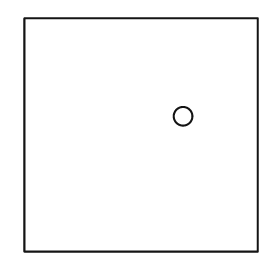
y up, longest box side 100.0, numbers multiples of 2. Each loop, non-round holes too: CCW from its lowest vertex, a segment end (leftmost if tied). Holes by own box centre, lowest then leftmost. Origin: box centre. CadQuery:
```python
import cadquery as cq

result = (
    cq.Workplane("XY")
    .moveTo(-50.0, -50.0)
    .lineTo(50.0, -50.0)
    .lineTo(50.0, 50.0)
    .lineTo(-50.0, 50.0)
    .close()
    .moveTo(18.0, 8.0)
    .circle(4.0)
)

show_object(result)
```